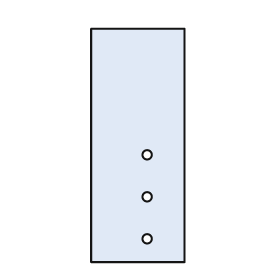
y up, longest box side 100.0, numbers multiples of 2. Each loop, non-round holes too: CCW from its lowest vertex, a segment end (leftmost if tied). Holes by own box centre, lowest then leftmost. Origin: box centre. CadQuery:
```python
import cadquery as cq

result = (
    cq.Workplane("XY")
    .moveTo(-20.0, -50.0)
    .lineTo(20.0, -50.0)
    .lineTo(20.0, 50.0)
    .lineTo(-20.0, 50.0)
    .close()
    .moveTo(4.0, -40.0)
    .circle(2.0)
    .moveTo(4.0, -22.0)
    .circle(2.0)
    .moveTo(4.0, -4.0)
    .circle(2.0)
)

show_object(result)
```